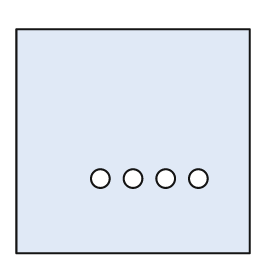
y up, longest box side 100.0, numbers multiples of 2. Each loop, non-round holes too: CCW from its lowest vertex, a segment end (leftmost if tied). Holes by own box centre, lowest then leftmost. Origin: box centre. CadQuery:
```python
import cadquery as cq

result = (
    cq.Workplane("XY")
    .moveTo(-50.0, -48.0)
    .lineTo(50.0, -48.0)
    .lineTo(50.0, 48.0)
    .lineTo(-50.0, 48.0)
    .close()
    .moveTo(-14.0, -16.0)
    .circle(4.0)
    .moveTo(0.0, -16.0)
    .circle(4.0)
    .moveTo(14.0, -16.0)
    .circle(4.0)
    .moveTo(28.0, -16.0)
    .circle(4.0)
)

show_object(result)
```